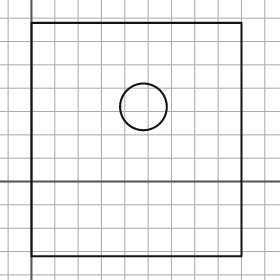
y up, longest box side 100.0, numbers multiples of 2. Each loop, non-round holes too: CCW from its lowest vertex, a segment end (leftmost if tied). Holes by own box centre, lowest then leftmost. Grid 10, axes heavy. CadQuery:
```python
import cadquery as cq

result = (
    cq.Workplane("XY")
    .moveTo(0.0, -32.0)
    .lineTo(90.0, -32.0)
    .lineTo(90.0, 68.0)
    .lineTo(0.0, 68.0)
    .close()
    .moveTo(48.0, 32.0)
    .circle(10.0)
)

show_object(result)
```